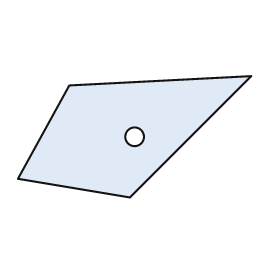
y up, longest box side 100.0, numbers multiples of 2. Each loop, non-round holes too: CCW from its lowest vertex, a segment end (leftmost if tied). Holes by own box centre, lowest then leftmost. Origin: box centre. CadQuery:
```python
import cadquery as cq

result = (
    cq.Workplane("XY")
    .moveTo(-2.0, -26.0)
    .lineTo(50.0, 26.0)
    .lineTo(-28.0, 22.0)
    .lineTo(-50.0, -18.0)
    .close()
    .moveTo(0.0, 0.0)
    .circle(4.0)
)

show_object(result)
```